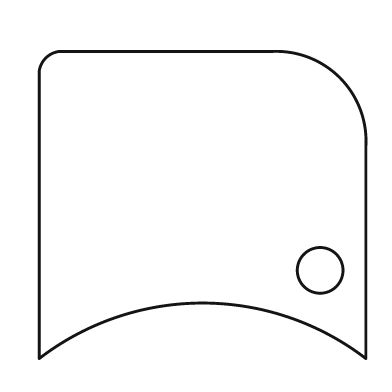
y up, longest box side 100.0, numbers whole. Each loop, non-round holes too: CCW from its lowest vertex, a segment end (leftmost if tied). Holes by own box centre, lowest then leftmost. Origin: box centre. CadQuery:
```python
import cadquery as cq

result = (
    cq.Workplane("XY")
    .moveTo(-50.0, -47.0)
    .threePointArc((0.0, -30.0), (50.0, -47.0))
    .lineTo(50.0, 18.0)
    .threePointArc((42.0, 39.0), (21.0, 47.0))
    .lineTo(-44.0, 47.0)
    .threePointArc((-48.0, 45.0), (-50.0, 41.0))
    .close()
    .moveTo(36.0, -20.0)
    .circle(7.0)
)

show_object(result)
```